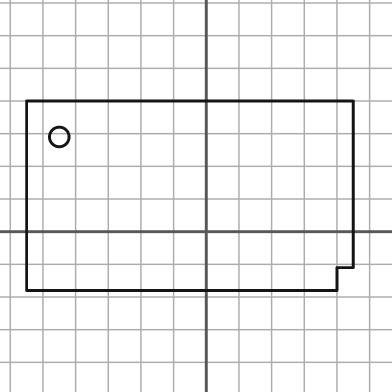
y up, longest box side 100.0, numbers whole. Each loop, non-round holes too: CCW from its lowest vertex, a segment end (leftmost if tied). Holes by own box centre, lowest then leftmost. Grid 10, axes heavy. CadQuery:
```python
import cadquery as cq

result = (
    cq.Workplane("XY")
    .moveTo(-55.0, -18.0)
    .lineTo(40.0, -18.0)
    .lineTo(40.0, -11.0)
    .lineTo(45.0, -11.0)
    .lineTo(45.0, 40.0)
    .lineTo(-55.0, 40.0)
    .close()
    .moveTo(-45.0, 29.0)
    .circle(3.0)
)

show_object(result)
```